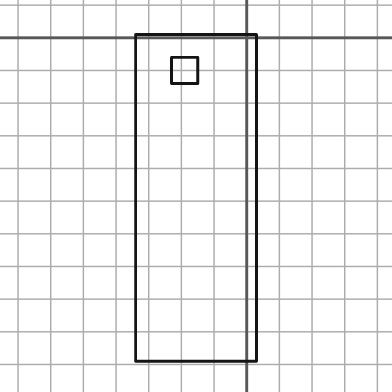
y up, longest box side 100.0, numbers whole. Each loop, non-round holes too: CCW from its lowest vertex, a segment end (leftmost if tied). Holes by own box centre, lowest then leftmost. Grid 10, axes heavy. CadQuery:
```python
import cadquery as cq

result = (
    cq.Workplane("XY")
    .moveTo(-34.0, -99.0)
    .lineTo(3.0, -99.0)
    .lineTo(3.0, 1.0)
    .lineTo(-34.0, 1.0)
    .close()
    .moveTo(-23.0, -14.0)
    .lineTo(-15.0, -14.0)
    .lineTo(-15.0, -6.0)
    .lineTo(-23.0, -6.0)
    .close()
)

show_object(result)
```